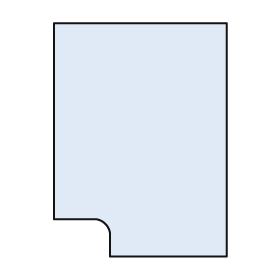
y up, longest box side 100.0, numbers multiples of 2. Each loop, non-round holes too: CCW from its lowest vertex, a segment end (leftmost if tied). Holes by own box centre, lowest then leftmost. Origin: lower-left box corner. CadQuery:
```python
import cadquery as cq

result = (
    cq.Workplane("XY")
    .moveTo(24.0, 0.0)
    .lineTo(74.0, 0.0)
    .lineTo(74.0, 100.0)
    .lineTo(0.0, 100.0)
    .lineTo(0.0, 16.0)
    .lineTo(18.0, 16.0)
    .threePointArc((22.0, 14.0), (24.0, 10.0))
    .close()
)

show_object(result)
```